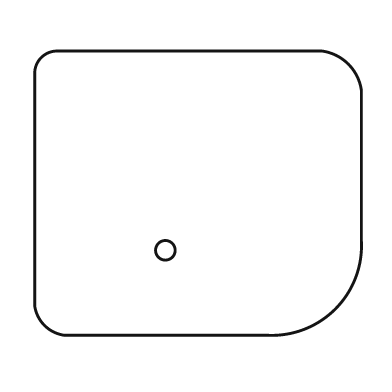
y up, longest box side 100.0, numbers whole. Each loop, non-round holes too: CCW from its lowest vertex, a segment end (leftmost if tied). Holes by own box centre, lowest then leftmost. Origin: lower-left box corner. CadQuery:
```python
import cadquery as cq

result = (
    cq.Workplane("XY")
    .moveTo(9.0, 0.0)
    .lineTo(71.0, 0.0)
    .threePointArc((92.0, 8.0), (100.0, 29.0))
    .lineTo(100.0, 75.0)
    .threePointArc((96.0, 83.0), (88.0, 87.0))
    .lineTo(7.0, 87.0)
    .threePointArc((2.0, 85.0), (0.0, 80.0))
    .lineTo(0.0, 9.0)
    .threePointArc((3.0, 3.0), (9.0, 0.0))
    .close()
    .moveTo(40.0, 26.0)
    .circle(3.0)
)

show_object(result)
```